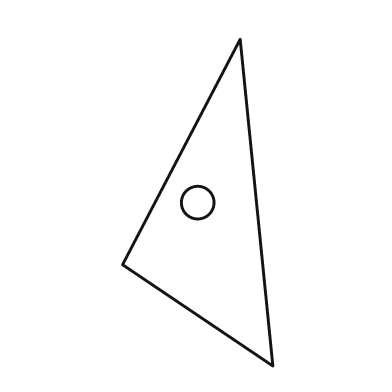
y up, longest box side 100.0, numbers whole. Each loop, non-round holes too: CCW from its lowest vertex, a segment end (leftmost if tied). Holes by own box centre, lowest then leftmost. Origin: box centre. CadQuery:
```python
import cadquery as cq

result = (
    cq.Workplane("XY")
    .moveTo(23.0, -50.0)
    .lineTo(13.0, 50.0)
    .lineTo(-23.0, -19.0)
    .close()
    .moveTo(0.0, 0.0)
    .circle(5.0)
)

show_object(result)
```